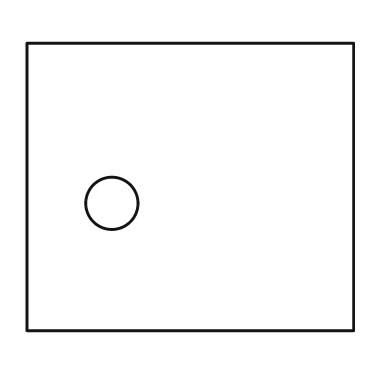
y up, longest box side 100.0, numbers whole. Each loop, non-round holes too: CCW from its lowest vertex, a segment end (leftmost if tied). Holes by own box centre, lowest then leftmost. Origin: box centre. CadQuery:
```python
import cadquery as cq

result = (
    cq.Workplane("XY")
    .moveTo(-50.0, -44.0)
    .lineTo(50.0, -44.0)
    .lineTo(50.0, 44.0)
    .lineTo(-50.0, 44.0)
    .close()
    .moveTo(-24.0, -5.0)
    .circle(8.0)
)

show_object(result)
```